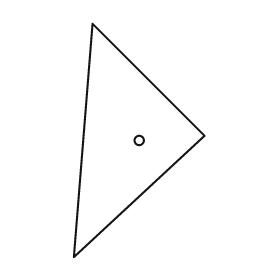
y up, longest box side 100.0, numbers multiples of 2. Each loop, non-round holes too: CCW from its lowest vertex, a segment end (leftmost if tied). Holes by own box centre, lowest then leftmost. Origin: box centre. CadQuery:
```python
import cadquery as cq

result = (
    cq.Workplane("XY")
    .moveTo(-28.0, -50.0)
    .lineTo(28.0, 2.0)
    .lineTo(-20.0, 50.0)
    .close()
    .moveTo(0.0, 0.0)
    .circle(2.0)
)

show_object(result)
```